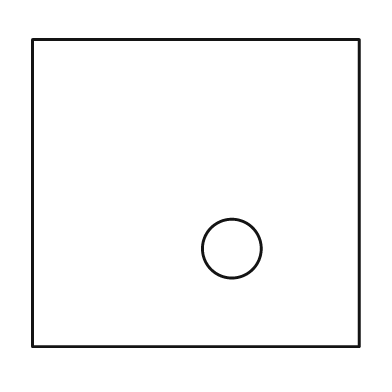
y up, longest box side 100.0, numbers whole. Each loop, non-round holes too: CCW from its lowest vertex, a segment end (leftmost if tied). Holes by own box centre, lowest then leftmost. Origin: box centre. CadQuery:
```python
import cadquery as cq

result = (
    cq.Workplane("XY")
    .moveTo(-50.0, -47.0)
    .lineTo(50.0, -47.0)
    .lineTo(50.0, 47.0)
    .lineTo(-50.0, 47.0)
    .close()
    .moveTo(11.0, -17.0)
    .circle(9.0)
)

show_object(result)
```